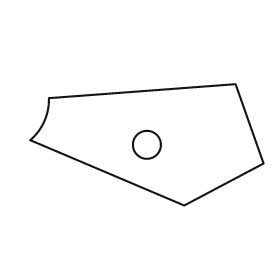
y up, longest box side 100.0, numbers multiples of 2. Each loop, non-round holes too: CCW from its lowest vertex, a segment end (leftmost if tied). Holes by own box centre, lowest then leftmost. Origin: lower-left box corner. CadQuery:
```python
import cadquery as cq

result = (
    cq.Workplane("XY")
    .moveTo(66.0, 0.0)
    .lineTo(100.0, 18.0)
    .lineTo(88.0, 52.0)
    .lineTo(8.0, 46.0)
    .threePointArc((6.0, 36.0), (0.0, 28.0))
    .close()
    .moveTo(50.0, 26.0)
    .circle(6.0)
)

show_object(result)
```